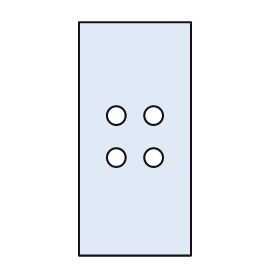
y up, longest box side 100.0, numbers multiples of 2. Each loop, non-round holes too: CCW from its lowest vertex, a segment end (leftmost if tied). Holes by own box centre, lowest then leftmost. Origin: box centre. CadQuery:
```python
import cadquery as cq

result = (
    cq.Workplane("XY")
    .moveTo(-24.0, -50.0)
    .lineTo(24.0, -50.0)
    .lineTo(24.0, 50.0)
    .lineTo(-24.0, 50.0)
    .close()
    .moveTo(-8.0, -8.0)
    .circle(4.0)
    .moveTo(8.0, -8.0)
    .circle(4.0)
    .moveTo(-8.0, 10.0)
    .circle(4.0)
    .moveTo(8.0, 10.0)
    .circle(4.0)
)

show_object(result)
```